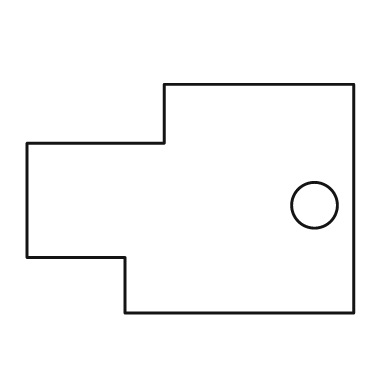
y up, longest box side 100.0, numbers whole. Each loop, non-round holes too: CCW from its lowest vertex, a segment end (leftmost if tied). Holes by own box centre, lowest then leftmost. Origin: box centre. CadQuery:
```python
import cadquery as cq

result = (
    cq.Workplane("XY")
    .moveTo(-20.0, -35.0)
    .lineTo(50.0, -35.0)
    .lineTo(50.0, 35.0)
    .lineTo(-8.0, 35.0)
    .lineTo(-8.0, 17.0)
    .lineTo(-50.0, 17.0)
    .lineTo(-50.0, -18.0)
    .lineTo(-20.0, -18.0)
    .close()
    .moveTo(38.0, -2.0)
    .circle(7.0)
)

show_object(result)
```